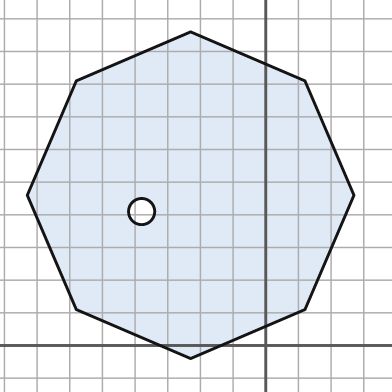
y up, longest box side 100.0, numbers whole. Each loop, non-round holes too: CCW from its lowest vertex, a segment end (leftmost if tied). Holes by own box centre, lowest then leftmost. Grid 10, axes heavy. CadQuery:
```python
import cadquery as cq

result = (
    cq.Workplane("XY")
    .moveTo(-23.0, -4.0)
    .lineTo(12.0, 11.0)
    .lineTo(27.0, 46.0)
    .lineTo(12.0, 81.0)
    .lineTo(-23.0, 96.0)
    .lineTo(-58.0, 81.0)
    .lineTo(-73.0, 46.0)
    .lineTo(-58.0, 11.0)
    .close()
    .moveTo(-38.0, 41.0)
    .circle(4.0)
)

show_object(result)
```